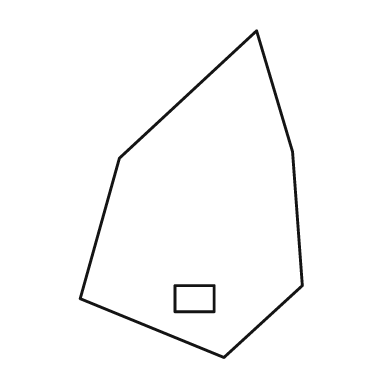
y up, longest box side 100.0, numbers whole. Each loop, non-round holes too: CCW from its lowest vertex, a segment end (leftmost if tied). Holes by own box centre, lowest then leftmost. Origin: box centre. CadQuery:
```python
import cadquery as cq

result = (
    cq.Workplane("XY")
    .moveTo(10.0, -50.0)
    .lineTo(34.0, -28.0)
    .lineTo(31.0, 13.0)
    .lineTo(20.0, 50.0)
    .lineTo(-22.0, 11.0)
    .lineTo(-34.0, -32.0)
    .close()
    .moveTo(-5.0, -36.0)
    .lineTo(7.0, -36.0)
    .lineTo(7.0, -28.0)
    .lineTo(-5.0, -28.0)
    .close()
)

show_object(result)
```